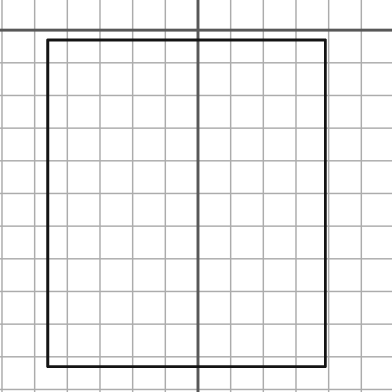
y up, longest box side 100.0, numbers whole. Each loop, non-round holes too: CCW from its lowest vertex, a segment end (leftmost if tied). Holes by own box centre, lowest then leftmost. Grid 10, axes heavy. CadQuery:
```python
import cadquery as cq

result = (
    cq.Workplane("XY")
    .moveTo(-46.0, -103.0)
    .lineTo(39.0, -103.0)
    .lineTo(39.0, -3.0)
    .lineTo(-46.0, -3.0)
    .close()
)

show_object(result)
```